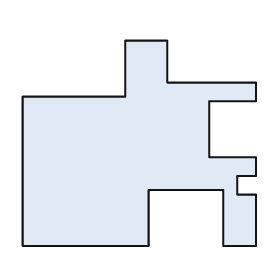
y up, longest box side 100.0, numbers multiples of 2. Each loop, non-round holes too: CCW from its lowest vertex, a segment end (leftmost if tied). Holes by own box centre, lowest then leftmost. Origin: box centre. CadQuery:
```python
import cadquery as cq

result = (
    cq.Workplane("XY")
    .moveTo(-50.0, -44.0)
    .lineTo(4.0, -44.0)
    .lineTo(4.0, -20.0)
    .lineTo(36.0, -20.0)
    .lineTo(36.0, -44.0)
    .lineTo(50.0, -44.0)
    .lineTo(50.0, -22.0)
    .lineTo(42.0, -22.0)
    .lineTo(42.0, -14.0)
    .lineTo(50.0, -14.0)
    .lineTo(50.0, -6.0)
    .lineTo(30.0, -6.0)
    .lineTo(30.0, 18.0)
    .lineTo(50.0, 18.0)
    .lineTo(50.0, 26.0)
    .lineTo(12.0, 26.0)
    .lineTo(12.0, 44.0)
    .lineTo(-6.0, 44.0)
    .lineTo(-6.0, 20.0)
    .lineTo(-50.0, 20.0)
    .close()
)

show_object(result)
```